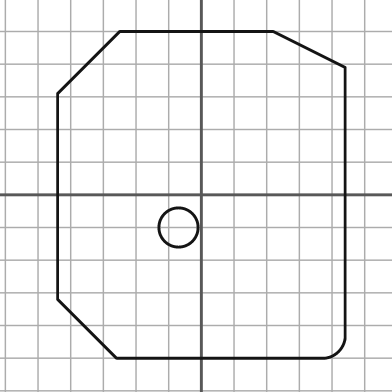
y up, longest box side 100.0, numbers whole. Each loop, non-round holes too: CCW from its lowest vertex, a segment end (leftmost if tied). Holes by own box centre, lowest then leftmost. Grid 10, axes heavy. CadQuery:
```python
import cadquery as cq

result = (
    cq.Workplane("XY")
    .moveTo(-26.0, -50.0)
    .lineTo(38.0, -50.0)
    .threePointArc((42.0, -48.0), (44.0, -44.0))
    .lineTo(44.0, 39.0)
    .lineTo(22.0, 50.0)
    .lineTo(-25.0, 50.0)
    .lineTo(-44.0, 31.0)
    .lineTo(-44.0, -32.0)
    .close()
    .moveTo(-7.0, -10.0)
    .circle(6.0)
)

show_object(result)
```